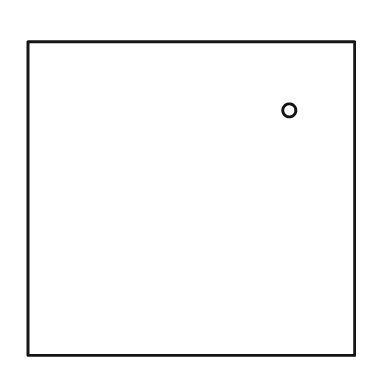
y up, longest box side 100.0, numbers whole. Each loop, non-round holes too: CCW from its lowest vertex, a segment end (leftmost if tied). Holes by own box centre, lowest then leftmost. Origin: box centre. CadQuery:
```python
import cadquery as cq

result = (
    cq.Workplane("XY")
    .moveTo(-50.0, -48.0)
    .lineTo(50.0, -48.0)
    .lineTo(50.0, 48.0)
    .lineTo(-50.0, 48.0)
    .close()
    .moveTo(30.0, 27.0)
    .circle(2.0)
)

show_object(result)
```